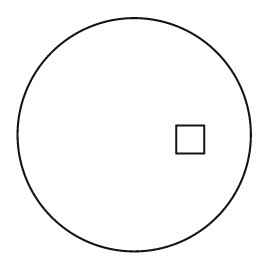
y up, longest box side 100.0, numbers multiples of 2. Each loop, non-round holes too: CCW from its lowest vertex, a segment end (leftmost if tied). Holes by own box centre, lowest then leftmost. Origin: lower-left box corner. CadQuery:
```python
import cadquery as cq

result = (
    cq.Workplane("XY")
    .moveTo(50.0, 50.0)
    .circle(50.0)
    .moveTo(68.0, 42.0)
    .lineTo(80.0, 42.0)
    .lineTo(80.0, 54.0)
    .lineTo(68.0, 54.0)
    .close()
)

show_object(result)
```